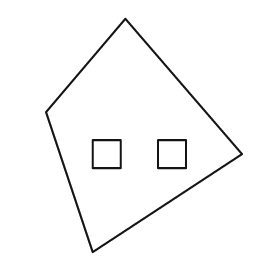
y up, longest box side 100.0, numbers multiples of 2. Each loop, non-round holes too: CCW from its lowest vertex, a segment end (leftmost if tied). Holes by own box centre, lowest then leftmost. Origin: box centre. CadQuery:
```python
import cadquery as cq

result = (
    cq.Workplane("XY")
    .moveTo(-22.0, -50.0)
    .lineTo(42.0, -8.0)
    .lineTo(-8.0, 50.0)
    .lineTo(-42.0, 10.0)
    .close()
    .moveTo(-22.0, -14.0)
    .lineTo(-10.0, -14.0)
    .lineTo(-10.0, -2.0)
    .lineTo(-22.0, -2.0)
    .close()
    .moveTo(6.0, -14.0)
    .lineTo(18.0, -14.0)
    .lineTo(18.0, -2.0)
    .lineTo(6.0, -2.0)
    .close()
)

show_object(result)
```